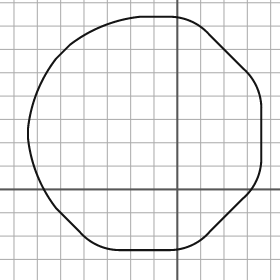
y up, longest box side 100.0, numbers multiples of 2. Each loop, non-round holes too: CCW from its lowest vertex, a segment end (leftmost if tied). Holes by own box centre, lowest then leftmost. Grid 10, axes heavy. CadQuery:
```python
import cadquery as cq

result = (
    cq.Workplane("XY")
    .moveTo(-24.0, -26.0)
    .lineTo(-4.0, -26.0)
    .threePointArc((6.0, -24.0), (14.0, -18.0))
    .lineTo(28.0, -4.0)
    .threePointArc((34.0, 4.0), (36.0, 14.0))
    .lineTo(36.0, 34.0)
    .threePointArc((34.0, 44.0), (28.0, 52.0))
    .lineTo(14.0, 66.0)
    .threePointArc((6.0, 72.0), (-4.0, 74.0))
    .lineTo(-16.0, 74.0)
    .threePointArc((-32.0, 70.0), (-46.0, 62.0))
    .lineTo(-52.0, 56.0)
    .threePointArc((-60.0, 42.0), (-64.0, 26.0))
    .lineTo(-64.0, 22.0)
    .threePointArc((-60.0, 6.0), (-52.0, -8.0))
    .lineTo(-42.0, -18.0)
    .threePointArc((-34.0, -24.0), (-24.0, -26.0))
    .close()
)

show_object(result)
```